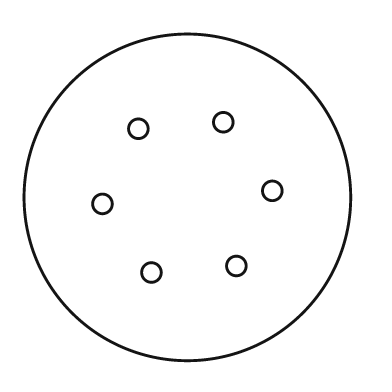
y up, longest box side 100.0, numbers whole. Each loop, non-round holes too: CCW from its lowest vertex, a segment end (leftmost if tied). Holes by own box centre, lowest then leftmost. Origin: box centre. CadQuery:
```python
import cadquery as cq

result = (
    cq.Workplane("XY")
    .moveTo(0.0, 0.0)
    .circle(50.0)
    .moveTo(-11.0, -23.0)
    .circle(3.0)
    .moveTo(15.0, -21.0)
    .circle(3.0)
    .moveTo(-26.0, -2.0)
    .circle(3.0)
    .moveTo(26.0, 2.0)
    .circle(3.0)
    .moveTo(-15.0, 21.0)
    .circle(3.0)
    .moveTo(11.0, 23.0)
    .circle(3.0)
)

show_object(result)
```